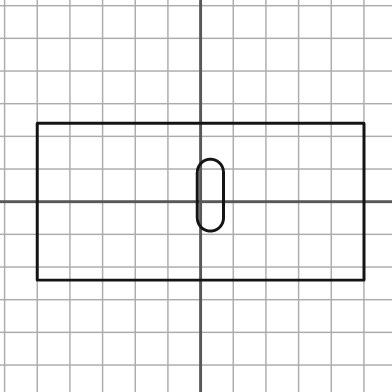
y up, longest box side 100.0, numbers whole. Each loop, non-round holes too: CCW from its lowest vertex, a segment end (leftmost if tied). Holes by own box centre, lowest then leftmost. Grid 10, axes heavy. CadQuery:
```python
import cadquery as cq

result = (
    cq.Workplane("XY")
    .moveTo(-50.0, -24.0)
    .lineTo(50.0, -24.0)
    .lineTo(50.0, 24.0)
    .lineTo(-50.0, 24.0)
    .close()
    .moveTo(-1.0, -5.0)
    .threePointArc((3.0, -9.0), (7.0, -5.0))
    .lineTo(7.0, 9.0)
    .threePointArc((3.0, 13.0), (-1.0, 9.0))
    .close()
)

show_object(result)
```